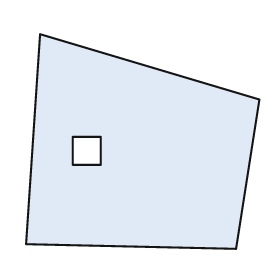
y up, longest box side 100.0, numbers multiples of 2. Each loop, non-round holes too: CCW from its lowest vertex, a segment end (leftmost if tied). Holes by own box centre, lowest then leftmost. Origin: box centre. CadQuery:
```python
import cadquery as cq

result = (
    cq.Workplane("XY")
    .moveTo(40.0, -46.0)
    .lineTo(50.0, 18.0)
    .lineTo(-44.0, 46.0)
    .lineTo(-50.0, -44.0)
    .close()
    .moveTo(-30.0, -10.0)
    .lineTo(-18.0, -10.0)
    .lineTo(-18.0, 2.0)
    .lineTo(-30.0, 2.0)
    .close()
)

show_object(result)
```